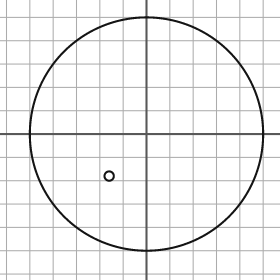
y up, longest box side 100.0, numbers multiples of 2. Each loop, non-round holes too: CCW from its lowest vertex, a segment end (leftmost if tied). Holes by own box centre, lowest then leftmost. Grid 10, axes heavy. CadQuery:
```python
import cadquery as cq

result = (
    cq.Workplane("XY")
    .moveTo(0.0, 0.0)
    .circle(50.0)
    .moveTo(-16.0, -18.0)
    .circle(2.0)
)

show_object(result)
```